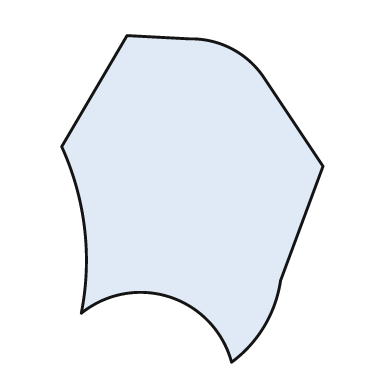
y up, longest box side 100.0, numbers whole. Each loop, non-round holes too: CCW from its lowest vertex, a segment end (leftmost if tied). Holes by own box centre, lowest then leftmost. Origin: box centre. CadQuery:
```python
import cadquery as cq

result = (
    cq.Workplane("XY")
    .moveTo(12.0, -50.0)
    .threePointArc((22.0, -39.0), (27.0, -25.0))
    .lineTo(40.0, 10.0)
    .lineTo(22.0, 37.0)
    .threePointArc((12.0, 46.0), (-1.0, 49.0))
    .lineTo(-20.0, 50.0)
    .lineTo(-40.0, 16.0)
    .threePointArc((-33.0, -9.0), (-34.0, -35.0))
    .threePointArc((-7.0, -30.0), (12.0, -50.0))
    .close()
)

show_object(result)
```